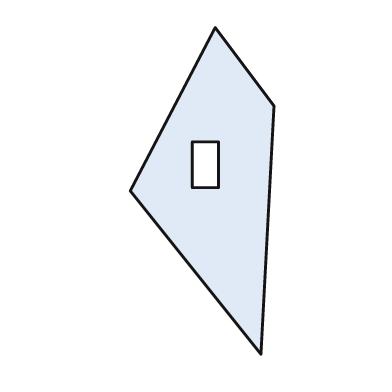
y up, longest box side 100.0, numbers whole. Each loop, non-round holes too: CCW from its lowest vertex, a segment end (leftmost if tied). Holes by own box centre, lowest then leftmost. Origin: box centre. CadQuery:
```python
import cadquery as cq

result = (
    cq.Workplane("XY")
    .moveTo(18.0, -50.0)
    .lineTo(22.0, 26.0)
    .lineTo(4.0, 50.0)
    .lineTo(-22.0, 0.0)
    .close()
    .moveTo(-3.0, 1.0)
    .lineTo(5.0, 1.0)
    .lineTo(5.0, 15.0)
    .lineTo(-3.0, 15.0)
    .close()
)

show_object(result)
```